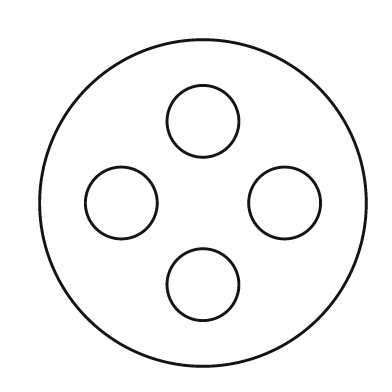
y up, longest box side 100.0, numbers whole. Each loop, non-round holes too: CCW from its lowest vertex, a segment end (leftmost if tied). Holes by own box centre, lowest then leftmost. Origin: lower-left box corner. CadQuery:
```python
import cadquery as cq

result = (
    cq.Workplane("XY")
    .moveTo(50.0, 50.0)
    .circle(50.0)
    .moveTo(50.0, 25.0)
    .circle(11.0)
    .moveTo(25.0, 50.0)
    .circle(11.0)
    .moveTo(75.0, 50.0)
    .circle(11.0)
    .moveTo(50.0, 75.0)
    .circle(11.0)
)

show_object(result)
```